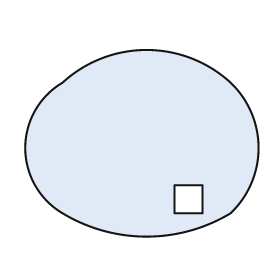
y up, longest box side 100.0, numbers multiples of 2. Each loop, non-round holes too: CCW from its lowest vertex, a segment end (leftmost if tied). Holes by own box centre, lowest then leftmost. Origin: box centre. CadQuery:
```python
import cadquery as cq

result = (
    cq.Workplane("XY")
    .moveTo(-34.0, -30.0)
    .threePointArc((2.0, -40.0), (38.0, -30.0))
    .threePointArc((50.0, -2.0), (38.0, 26.0))
    .threePointArc((2.0, 40.0), (-34.0, 26.0))
    .threePointArc((-50.0, -2.0), (-34.0, -30.0))
    .close()
    .moveTo(14.0, -30.0)
    .lineTo(26.0, -30.0)
    .lineTo(26.0, -18.0)
    .lineTo(14.0, -18.0)
    .close()
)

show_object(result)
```